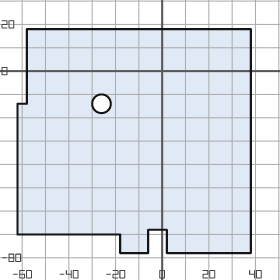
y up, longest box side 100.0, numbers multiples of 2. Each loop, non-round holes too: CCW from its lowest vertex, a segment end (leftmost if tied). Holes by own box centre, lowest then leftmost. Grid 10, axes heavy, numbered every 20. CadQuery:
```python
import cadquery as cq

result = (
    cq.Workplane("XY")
    .moveTo(-18.0, -78.0)
    .lineTo(-6.0, -78.0)
    .lineTo(-6.0, -68.0)
    .lineTo(2.0, -68.0)
    .lineTo(2.0, -78.0)
    .lineTo(38.0, -78.0)
    .lineTo(38.0, 18.0)
    .lineTo(-58.0, 18.0)
    .lineTo(-58.0, -14.0)
    .lineTo(-62.0, -14.0)
    .lineTo(-62.0, -70.0)
    .lineTo(-18.0, -70.0)
    .close()
    .moveTo(-26.0, -14.0)
    .circle(4.0)
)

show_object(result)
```